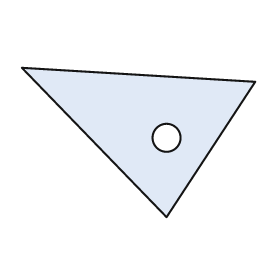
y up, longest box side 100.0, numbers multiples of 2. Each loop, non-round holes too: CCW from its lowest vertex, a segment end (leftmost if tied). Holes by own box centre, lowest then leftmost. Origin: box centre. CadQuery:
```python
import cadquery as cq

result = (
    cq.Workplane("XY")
    .moveTo(12.0, -32.0)
    .lineTo(50.0, 26.0)
    .lineTo(-50.0, 32.0)
    .close()
    .moveTo(12.0, 2.0)
    .circle(6.0)
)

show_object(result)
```